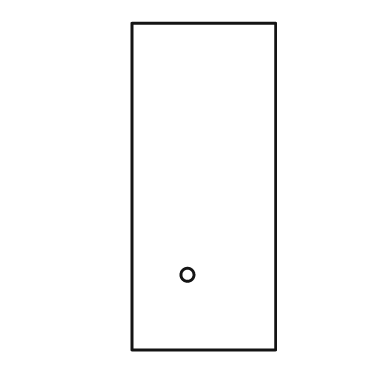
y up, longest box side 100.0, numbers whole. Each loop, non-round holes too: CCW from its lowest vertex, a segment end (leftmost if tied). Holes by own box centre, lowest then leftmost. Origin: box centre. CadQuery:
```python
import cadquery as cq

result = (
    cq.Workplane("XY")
    .moveTo(-22.0, -50.0)
    .lineTo(22.0, -50.0)
    .lineTo(22.0, 50.0)
    .lineTo(-22.0, 50.0)
    .close()
    .moveTo(-5.0, -27.0)
    .circle(2.0)
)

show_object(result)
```